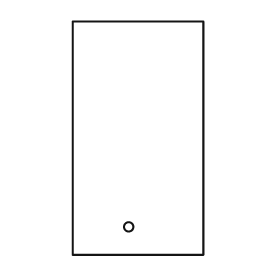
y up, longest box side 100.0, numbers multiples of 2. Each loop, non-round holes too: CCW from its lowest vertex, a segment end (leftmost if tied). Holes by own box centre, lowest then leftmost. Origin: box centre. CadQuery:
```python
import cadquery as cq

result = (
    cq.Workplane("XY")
    .moveTo(-28.0, -50.0)
    .lineTo(28.0, -50.0)
    .lineTo(28.0, 50.0)
    .lineTo(-28.0, 50.0)
    .close()
    .moveTo(-4.0, -38.0)
    .circle(2.0)
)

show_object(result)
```